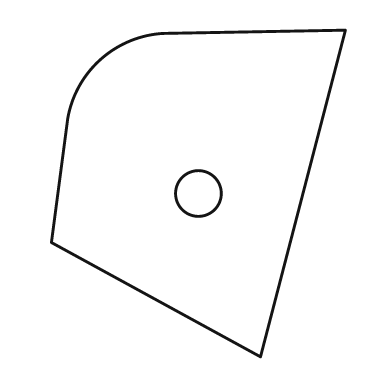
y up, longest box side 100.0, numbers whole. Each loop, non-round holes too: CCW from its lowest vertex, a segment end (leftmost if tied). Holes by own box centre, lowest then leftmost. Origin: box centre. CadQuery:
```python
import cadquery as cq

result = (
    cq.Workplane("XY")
    .moveTo(19.0, -50.0)
    .lineTo(45.0, 50.0)
    .lineTo(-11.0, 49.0)
    .threePointArc((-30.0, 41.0), (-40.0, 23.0))
    .lineTo(-45.0, -15.0)
    .close()
    .moveTo(0.0, 0.0)
    .circle(7.0)
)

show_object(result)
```